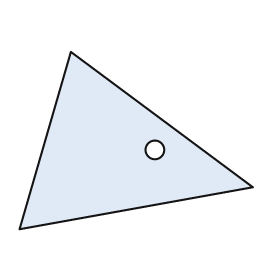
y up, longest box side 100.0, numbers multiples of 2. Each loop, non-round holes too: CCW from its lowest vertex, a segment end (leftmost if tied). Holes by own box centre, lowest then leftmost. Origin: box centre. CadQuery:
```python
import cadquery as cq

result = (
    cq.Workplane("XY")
    .moveTo(-50.0, -38.0)
    .lineTo(50.0, -20.0)
    .lineTo(-28.0, 38.0)
    .close()
    .moveTo(8.0, -4.0)
    .circle(4.0)
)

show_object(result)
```